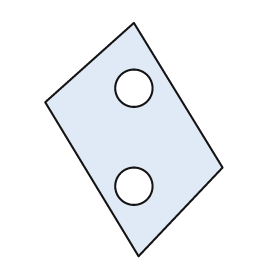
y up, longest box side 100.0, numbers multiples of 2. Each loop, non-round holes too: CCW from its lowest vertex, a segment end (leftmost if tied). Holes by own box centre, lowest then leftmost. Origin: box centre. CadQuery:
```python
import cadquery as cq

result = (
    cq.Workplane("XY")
    .moveTo(2.0, -50.0)
    .lineTo(38.0, -12.0)
    .lineTo(0.0, 50.0)
    .lineTo(-38.0, 16.0)
    .close()
    .moveTo(0.0, -20.0)
    .circle(8.0)
    .moveTo(0.0, 22.0)
    .circle(8.0)
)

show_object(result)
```